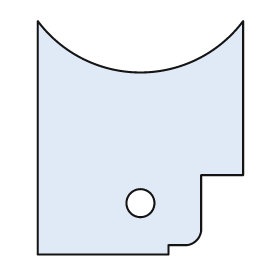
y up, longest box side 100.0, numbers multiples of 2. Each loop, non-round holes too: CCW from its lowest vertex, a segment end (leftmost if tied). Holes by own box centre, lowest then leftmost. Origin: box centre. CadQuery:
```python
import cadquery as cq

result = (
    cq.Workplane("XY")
    .moveTo(-44.0, -50.0)
    .lineTo(12.0, -50.0)
    .lineTo(12.0, -46.0)
    .lineTo(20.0, -46.0)
    .threePointArc((24.0, -44.0), (26.0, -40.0))
    .lineTo(26.0, -16.0)
    .lineTo(44.0, -16.0)
    .lineTo(44.0, 50.0)
    .threePointArc((0.0, 28.0), (-44.0, 50.0))
    .close()
    .moveTo(0.0, -28.0)
    .circle(6.0)
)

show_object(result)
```